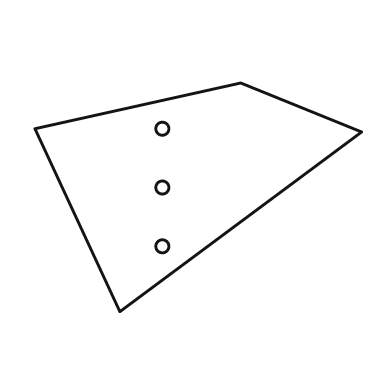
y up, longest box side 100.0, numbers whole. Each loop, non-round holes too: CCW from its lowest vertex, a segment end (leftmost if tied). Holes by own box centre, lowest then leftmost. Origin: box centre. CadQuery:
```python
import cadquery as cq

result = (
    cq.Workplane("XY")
    .moveTo(-24.0, -35.0)
    .lineTo(50.0, 20.0)
    .lineTo(13.0, 35.0)
    .lineTo(-50.0, 21.0)
    .close()
    .moveTo(-11.0, -15.0)
    .circle(2.0)
    .moveTo(-11.0, 3.0)
    .circle(2.0)
    .moveTo(-11.0, 21.0)
    .circle(2.0)
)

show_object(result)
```